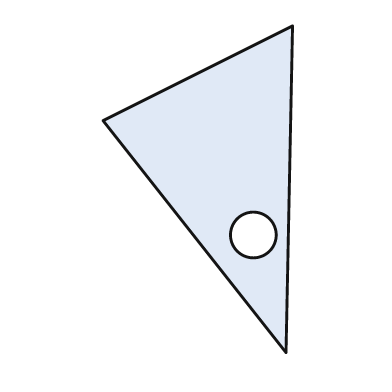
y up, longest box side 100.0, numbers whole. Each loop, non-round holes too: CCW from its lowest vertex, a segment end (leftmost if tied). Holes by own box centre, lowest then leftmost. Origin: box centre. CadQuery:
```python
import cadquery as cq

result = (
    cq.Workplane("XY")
    .moveTo(27.0, -50.0)
    .lineTo(29.0, 50.0)
    .lineTo(-29.0, 21.0)
    .close()
    .moveTo(17.0, -14.0)
    .circle(7.0)
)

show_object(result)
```